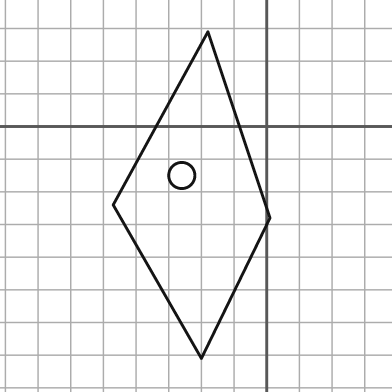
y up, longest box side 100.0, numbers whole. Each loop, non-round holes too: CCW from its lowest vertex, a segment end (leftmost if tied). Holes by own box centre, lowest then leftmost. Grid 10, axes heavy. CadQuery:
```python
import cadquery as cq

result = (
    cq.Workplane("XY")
    .moveTo(-20.0, -71.0)
    .lineTo(1.0, -28.0)
    .lineTo(-18.0, 29.0)
    .lineTo(-47.0, -24.0)
    .close()
    .moveTo(-26.0, -15.0)
    .circle(4.0)
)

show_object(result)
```